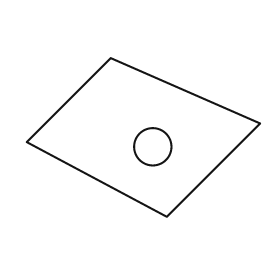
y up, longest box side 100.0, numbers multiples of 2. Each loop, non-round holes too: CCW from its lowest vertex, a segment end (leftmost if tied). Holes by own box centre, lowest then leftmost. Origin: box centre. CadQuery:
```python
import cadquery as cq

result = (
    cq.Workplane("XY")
    .moveTo(10.0, -34.0)
    .lineTo(50.0, 6.0)
    .lineTo(-14.0, 34.0)
    .lineTo(-50.0, -2.0)
    .close()
    .moveTo(4.0, -4.0)
    .circle(8.0)
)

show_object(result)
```